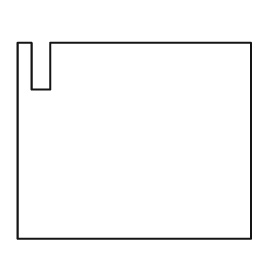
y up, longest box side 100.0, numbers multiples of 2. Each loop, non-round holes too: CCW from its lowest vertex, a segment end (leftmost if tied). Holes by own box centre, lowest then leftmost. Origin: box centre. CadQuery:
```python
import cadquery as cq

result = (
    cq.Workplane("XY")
    .moveTo(-50.0, -42.0)
    .lineTo(50.0, -42.0)
    .lineTo(50.0, 42.0)
    .lineTo(-36.0, 42.0)
    .lineTo(-36.0, 22.0)
    .lineTo(-44.0, 22.0)
    .lineTo(-44.0, 42.0)
    .lineTo(-50.0, 42.0)
    .close()
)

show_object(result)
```